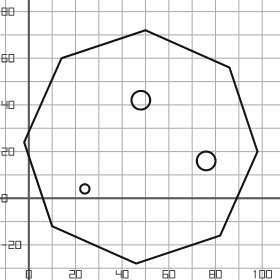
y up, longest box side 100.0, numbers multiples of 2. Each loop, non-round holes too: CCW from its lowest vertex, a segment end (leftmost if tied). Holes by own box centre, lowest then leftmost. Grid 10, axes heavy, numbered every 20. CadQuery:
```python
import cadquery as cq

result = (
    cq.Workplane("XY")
    .moveTo(46.0, -28.0)
    .lineTo(82.0, -16.0)
    .lineTo(98.0, 20.0)
    .lineTo(86.0, 56.0)
    .lineTo(50.0, 72.0)
    .lineTo(14.0, 60.0)
    .lineTo(-2.0, 24.0)
    .lineTo(10.0, -12.0)
    .close()
    .moveTo(24.0, 4.0)
    .circle(2.0)
    .moveTo(76.0, 16.0)
    .circle(4.0)
    .moveTo(48.0, 42.0)
    .circle(4.0)
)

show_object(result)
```